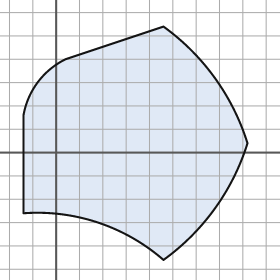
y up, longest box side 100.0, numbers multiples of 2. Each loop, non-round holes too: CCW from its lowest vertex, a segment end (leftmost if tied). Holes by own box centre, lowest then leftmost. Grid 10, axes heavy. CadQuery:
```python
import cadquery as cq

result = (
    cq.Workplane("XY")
    .moveTo(46.0, -46.0)
    .threePointArc((68.0, -24.0), (82.0, 4.0))
    .threePointArc((68.0, 32.0), (46.0, 54.0))
    .lineTo(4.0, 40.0)
    .threePointArc((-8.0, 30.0), (-14.0, 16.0))
    .lineTo(-14.0, -26.0)
    .threePointArc((18.0, -30.0), (46.0, -46.0))
    .close()
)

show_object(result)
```